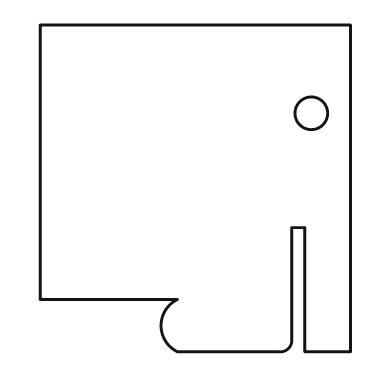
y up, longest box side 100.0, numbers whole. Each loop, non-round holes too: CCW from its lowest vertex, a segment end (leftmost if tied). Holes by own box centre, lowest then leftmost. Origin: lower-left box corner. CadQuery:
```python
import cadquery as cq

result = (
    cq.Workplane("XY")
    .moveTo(42.0, 0.0)
    .lineTo(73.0, 0.0)
    .threePointArc((76.0, 1.0), (77.0, 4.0))
    .lineTo(77.0, 38.0)
    .lineTo(81.0, 38.0)
    .lineTo(81.0, 0.0)
    .lineTo(95.0, 0.0)
    .lineTo(95.0, 100.0)
    .lineTo(0.0, 100.0)
    .lineTo(0.0, 16.0)
    .lineTo(42.0, 16.0)
    .threePointArc((37.0, 8.0), (42.0, 0.0))
    .close()
    .moveTo(83.0, 73.0)
    .circle(5.0)
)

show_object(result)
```